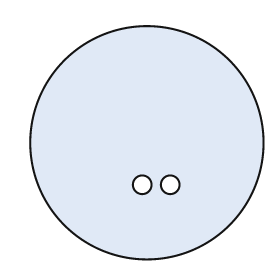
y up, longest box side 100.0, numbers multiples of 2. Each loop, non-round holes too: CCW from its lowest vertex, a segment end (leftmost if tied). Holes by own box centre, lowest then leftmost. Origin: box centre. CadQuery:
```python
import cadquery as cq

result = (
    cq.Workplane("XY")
    .moveTo(0.0, 0.0)
    .circle(50.0)
    .moveTo(-2.0, -18.0)
    .circle(4.0)
    .moveTo(10.0, -18.0)
    .circle(4.0)
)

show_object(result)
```